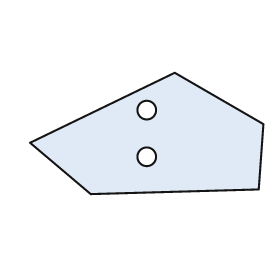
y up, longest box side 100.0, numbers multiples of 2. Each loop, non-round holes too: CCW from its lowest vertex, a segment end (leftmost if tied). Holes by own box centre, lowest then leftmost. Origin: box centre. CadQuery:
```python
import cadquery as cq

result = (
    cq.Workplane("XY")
    .moveTo(-24.0, -26.0)
    .lineTo(48.0, -24.0)
    .lineTo(50.0, 4.0)
    .lineTo(12.0, 26.0)
    .lineTo(-50.0, -4.0)
    .close()
    .moveTo(0.0, -10.0)
    .circle(4.0)
    .moveTo(0.0, 10.0)
    .circle(4.0)
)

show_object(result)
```